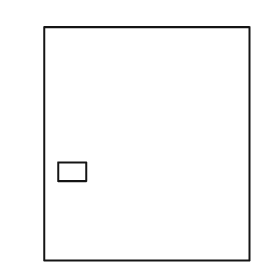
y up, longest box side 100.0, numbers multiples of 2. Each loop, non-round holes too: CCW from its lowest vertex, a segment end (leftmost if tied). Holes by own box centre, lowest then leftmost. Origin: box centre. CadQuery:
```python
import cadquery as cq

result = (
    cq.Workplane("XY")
    .moveTo(-44.0, -50.0)
    .lineTo(44.0, -50.0)
    .lineTo(44.0, 50.0)
    .lineTo(-44.0, 50.0)
    .close()
    .moveTo(-38.0, -16.0)
    .lineTo(-26.0, -16.0)
    .lineTo(-26.0, -8.0)
    .lineTo(-38.0, -8.0)
    .close()
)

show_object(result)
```